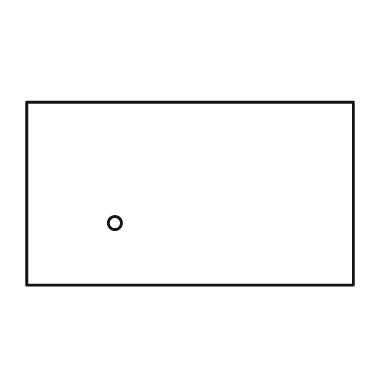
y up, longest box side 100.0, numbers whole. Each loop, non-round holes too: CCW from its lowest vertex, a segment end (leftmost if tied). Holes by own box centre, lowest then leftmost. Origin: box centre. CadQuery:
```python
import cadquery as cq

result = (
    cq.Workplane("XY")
    .moveTo(-50.0, -28.0)
    .lineTo(50.0, -28.0)
    .lineTo(50.0, 28.0)
    .lineTo(-50.0, 28.0)
    .close()
    .moveTo(-23.0, -9.0)
    .circle(2.0)
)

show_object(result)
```